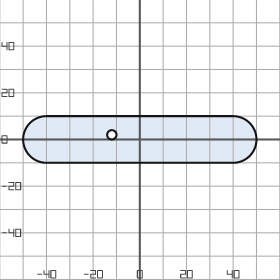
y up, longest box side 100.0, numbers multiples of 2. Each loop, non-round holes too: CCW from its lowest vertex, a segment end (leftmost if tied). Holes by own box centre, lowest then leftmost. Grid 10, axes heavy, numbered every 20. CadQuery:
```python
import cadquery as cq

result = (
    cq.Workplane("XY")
    .moveTo(-40.0, -10.0)
    .lineTo(40.0, -10.0)
    .threePointArc((50.0, 0.0), (40.0, 10.0))
    .lineTo(-40.0, 10.0)
    .threePointArc((-50.0, 0.0), (-40.0, -10.0))
    .close()
    .moveTo(-12.0, 2.0)
    .circle(2.0)
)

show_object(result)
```